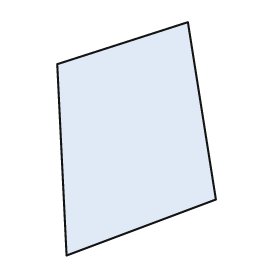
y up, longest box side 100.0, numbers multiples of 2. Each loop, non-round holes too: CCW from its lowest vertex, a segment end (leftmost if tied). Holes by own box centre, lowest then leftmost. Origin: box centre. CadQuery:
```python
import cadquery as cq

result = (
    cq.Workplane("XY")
    .moveTo(-30.0, -50.0)
    .lineTo(34.0, -26.0)
    .lineTo(22.0, 50.0)
    .lineTo(-34.0, 32.0)
    .close()
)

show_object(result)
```